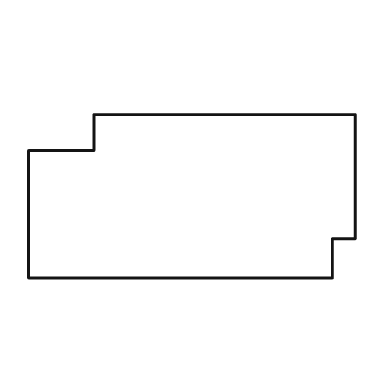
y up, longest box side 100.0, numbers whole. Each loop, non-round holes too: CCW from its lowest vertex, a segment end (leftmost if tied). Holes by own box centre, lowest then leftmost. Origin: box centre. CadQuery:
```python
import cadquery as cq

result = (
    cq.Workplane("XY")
    .moveTo(-50.0, -25.0)
    .lineTo(43.0, -25.0)
    .lineTo(43.0, -13.0)
    .lineTo(50.0, -13.0)
    .lineTo(50.0, 25.0)
    .lineTo(-30.0, 25.0)
    .lineTo(-30.0, 14.0)
    .lineTo(-50.0, 14.0)
    .close()
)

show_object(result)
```